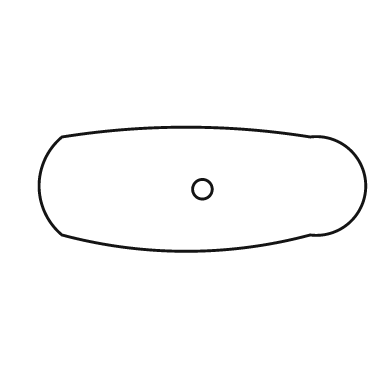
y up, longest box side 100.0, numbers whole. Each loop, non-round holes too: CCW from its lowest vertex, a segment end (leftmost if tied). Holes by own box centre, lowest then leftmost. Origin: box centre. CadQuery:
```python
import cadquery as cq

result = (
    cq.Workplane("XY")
    .moveTo(-43.0, -14.0)
    .threePointArc((-5.0, -19.0), (33.0, -14.0))
    .threePointArc((50.0, 1.0), (33.0, 16.0))
    .threePointArc((-5.0, 19.0), (-43.0, 16.0))
    .threePointArc((-50.0, 1.0), (-43.0, -14.0))
    .close()
    .moveTo(0.0, 0.0)
    .circle(3.0)
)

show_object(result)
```